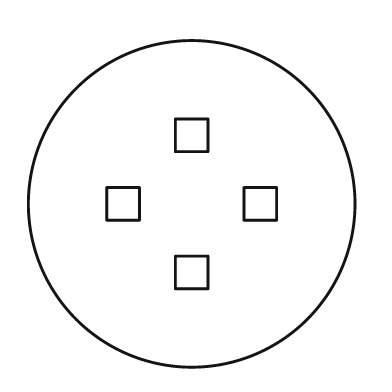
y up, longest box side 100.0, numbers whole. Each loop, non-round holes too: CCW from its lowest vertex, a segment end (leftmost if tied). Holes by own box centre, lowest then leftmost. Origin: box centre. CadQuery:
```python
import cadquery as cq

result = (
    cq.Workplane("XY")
    .moveTo(0.0, 0.0)
    .circle(50.0)
    .moveTo(-5.0, -26.0)
    .lineTo(5.0, -26.0)
    .lineTo(5.0, -16.0)
    .lineTo(-5.0, -16.0)
    .close()
    .moveTo(-26.0, -5.0)
    .lineTo(-16.0, -5.0)
    .lineTo(-16.0, 5.0)
    .lineTo(-26.0, 5.0)
    .close()
    .moveTo(16.0, -5.0)
    .lineTo(26.0, -5.0)
    .lineTo(26.0, 5.0)
    .lineTo(16.0, 5.0)
    .close()
    .moveTo(-5.0, 16.0)
    .lineTo(5.0, 16.0)
    .lineTo(5.0, 26.0)
    .lineTo(-5.0, 26.0)
    .close()
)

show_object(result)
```